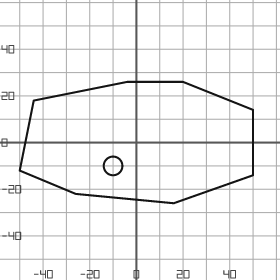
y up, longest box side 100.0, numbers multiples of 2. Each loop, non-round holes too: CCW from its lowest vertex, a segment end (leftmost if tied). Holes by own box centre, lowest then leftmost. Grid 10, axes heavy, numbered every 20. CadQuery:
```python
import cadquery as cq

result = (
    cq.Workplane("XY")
    .moveTo(16.0, -26.0)
    .lineTo(50.0, -14.0)
    .lineTo(50.0, 14.0)
    .lineTo(20.0, 26.0)
    .lineTo(-4.0, 26.0)
    .lineTo(-44.0, 18.0)
    .lineTo(-50.0, -12.0)
    .lineTo(-26.0, -22.0)
    .close()
    .moveTo(-10.0, -10.0)
    .circle(4.0)
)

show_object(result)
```